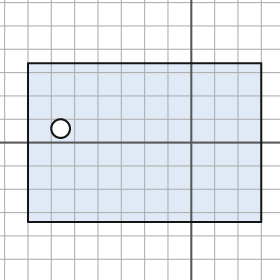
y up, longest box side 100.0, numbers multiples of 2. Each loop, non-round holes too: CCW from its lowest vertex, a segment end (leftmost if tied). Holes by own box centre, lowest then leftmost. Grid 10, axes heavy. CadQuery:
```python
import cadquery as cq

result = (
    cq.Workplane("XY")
    .moveTo(-70.0, -34.0)
    .lineTo(30.0, -34.0)
    .lineTo(30.0, 34.0)
    .lineTo(-70.0, 34.0)
    .close()
    .moveTo(-56.0, 6.0)
    .circle(4.0)
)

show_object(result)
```